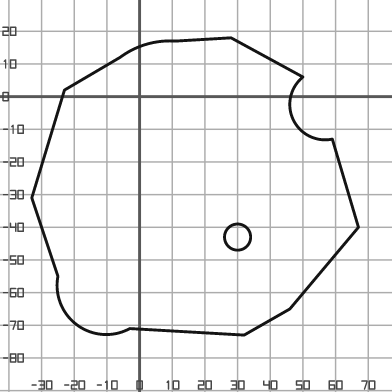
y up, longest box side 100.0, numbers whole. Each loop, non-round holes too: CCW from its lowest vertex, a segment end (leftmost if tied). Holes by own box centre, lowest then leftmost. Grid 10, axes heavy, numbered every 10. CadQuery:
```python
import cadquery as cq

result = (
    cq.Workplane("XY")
    .moveTo(32.0, -73.0)
    .lineTo(46.0, -65.0)
    .lineTo(67.0, -40.0)
    .lineTo(59.0, -13.0)
    .threePointArc((47.0, -7.0), (50.0, 6.0))
    .lineTo(28.0, 18.0)
    .lineTo(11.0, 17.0)
    .threePointArc((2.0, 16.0), (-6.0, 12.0))
    .lineTo(-23.0, 2.0)
    .lineTo(-33.0, -31.0)
    .lineTo(-25.0, -55.0)
    .threePointArc((-19.0, -70.0), (-3.0, -71.0))
    .close()
    .moveTo(30.0, -43.0)
    .circle(4.0)
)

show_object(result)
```